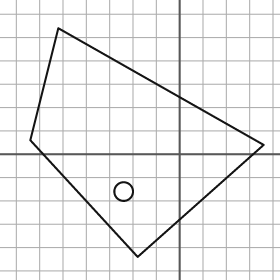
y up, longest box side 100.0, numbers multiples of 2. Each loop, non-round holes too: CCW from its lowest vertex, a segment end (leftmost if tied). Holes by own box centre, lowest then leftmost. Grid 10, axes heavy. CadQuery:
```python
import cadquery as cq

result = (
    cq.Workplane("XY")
    .moveTo(-18.0, -44.0)
    .lineTo(36.0, 4.0)
    .lineTo(-52.0, 54.0)
    .lineTo(-64.0, 6.0)
    .close()
    .moveTo(-24.0, -16.0)
    .circle(4.0)
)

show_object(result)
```